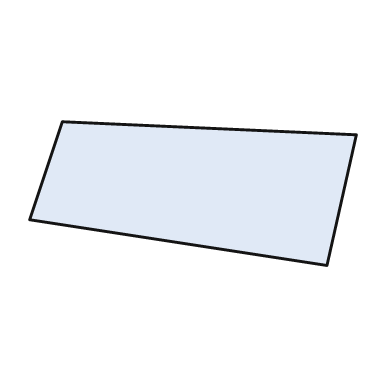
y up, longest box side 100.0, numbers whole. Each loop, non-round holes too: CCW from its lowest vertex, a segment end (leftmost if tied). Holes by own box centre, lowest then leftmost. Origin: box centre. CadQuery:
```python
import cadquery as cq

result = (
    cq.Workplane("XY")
    .moveTo(41.0, -22.0)
    .lineTo(50.0, 18.0)
    .lineTo(-40.0, 22.0)
    .lineTo(-50.0, -8.0)
    .close()
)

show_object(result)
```